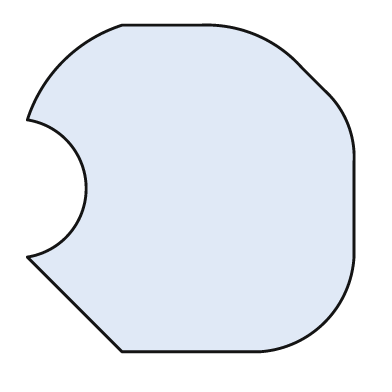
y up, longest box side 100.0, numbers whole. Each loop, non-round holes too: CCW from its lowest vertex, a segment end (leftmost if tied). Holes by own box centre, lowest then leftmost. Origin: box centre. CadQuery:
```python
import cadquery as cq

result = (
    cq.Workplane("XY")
    .moveTo(-21.0, -50.0)
    .lineTo(21.0, -50.0)
    .threePointArc((41.0, -41.0), (50.0, -21.0))
    .lineTo(50.0, 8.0)
    .threePointArc((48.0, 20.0), (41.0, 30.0))
    .lineTo(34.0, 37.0)
    .threePointArc((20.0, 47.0), (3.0, 50.0))
    .lineTo(-21.0, 50.0)
    .threePointArc((-39.0, 39.0), (-50.0, 21.0))
    .threePointArc((-32.0, 0.0), (-50.0, -21.0))
    .close()
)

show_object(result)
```